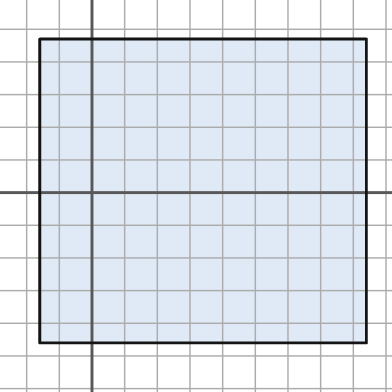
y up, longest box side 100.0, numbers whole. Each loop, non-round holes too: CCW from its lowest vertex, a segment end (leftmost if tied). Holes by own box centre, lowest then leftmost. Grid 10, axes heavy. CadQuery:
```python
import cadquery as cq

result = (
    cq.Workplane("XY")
    .moveTo(-16.0, -46.0)
    .lineTo(84.0, -46.0)
    .lineTo(84.0, 47.0)
    .lineTo(-16.0, 47.0)
    .close()
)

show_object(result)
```